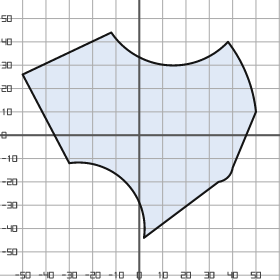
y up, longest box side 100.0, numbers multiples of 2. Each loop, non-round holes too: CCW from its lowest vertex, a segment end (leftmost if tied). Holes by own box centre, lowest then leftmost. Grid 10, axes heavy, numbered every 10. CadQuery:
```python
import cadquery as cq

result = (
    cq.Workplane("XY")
    .moveTo(2.0, -44.0)
    .lineTo(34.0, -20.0)
    .threePointArc((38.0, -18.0), (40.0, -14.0))
    .lineTo(50.0, 10.0)
    .threePointArc((46.0, 26.0), (38.0, 40.0))
    .threePointArc((12.0, 30.0), (-12.0, 44.0))
    .lineTo(-50.0, 26.0)
    .lineTo(-30.0, -12.0)
    .threePointArc((-6.0, -20.0), (2.0, -44.0))
    .close()
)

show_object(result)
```